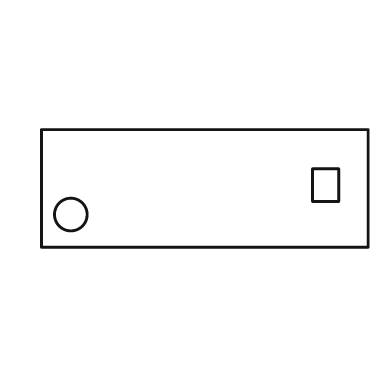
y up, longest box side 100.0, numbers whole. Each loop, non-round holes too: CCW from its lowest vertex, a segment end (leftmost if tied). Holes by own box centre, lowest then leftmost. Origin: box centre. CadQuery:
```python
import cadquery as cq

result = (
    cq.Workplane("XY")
    .moveTo(-50.0, -18.0)
    .lineTo(50.0, -18.0)
    .lineTo(50.0, 18.0)
    .lineTo(-50.0, 18.0)
    .close()
    .moveTo(-41.0, -8.0)
    .circle(5.0)
    .moveTo(33.0, -4.0)
    .lineTo(41.0, -4.0)
    .lineTo(41.0, 6.0)
    .lineTo(33.0, 6.0)
    .close()
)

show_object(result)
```